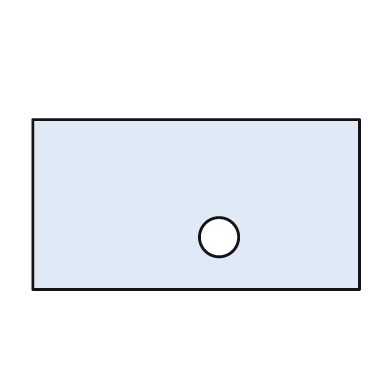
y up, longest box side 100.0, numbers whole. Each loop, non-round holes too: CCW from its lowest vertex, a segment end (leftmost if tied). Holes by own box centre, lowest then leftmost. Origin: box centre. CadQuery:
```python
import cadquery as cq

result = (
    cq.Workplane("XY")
    .moveTo(-50.0, -26.0)
    .lineTo(50.0, -26.0)
    .lineTo(50.0, 26.0)
    .lineTo(-50.0, 26.0)
    .close()
    .moveTo(7.0, -10.0)
    .circle(6.0)
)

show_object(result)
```